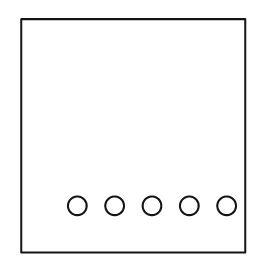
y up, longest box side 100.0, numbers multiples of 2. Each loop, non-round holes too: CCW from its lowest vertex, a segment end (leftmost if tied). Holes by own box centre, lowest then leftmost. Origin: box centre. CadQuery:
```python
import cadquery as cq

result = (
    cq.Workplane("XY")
    .moveTo(-48.0, -50.0)
    .lineTo(48.0, -50.0)
    .lineTo(48.0, 50.0)
    .lineTo(-48.0, 50.0)
    .close()
    .moveTo(-24.0, -30.0)
    .circle(4.0)
    .moveTo(-8.0, -30.0)
    .circle(4.0)
    .moveTo(8.0, -30.0)
    .circle(4.0)
    .moveTo(24.0, -30.0)
    .circle(4.0)
    .moveTo(40.0, -30.0)
    .circle(4.0)
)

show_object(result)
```